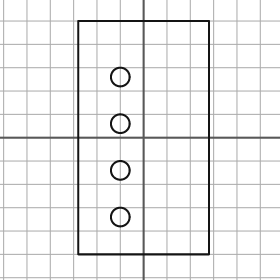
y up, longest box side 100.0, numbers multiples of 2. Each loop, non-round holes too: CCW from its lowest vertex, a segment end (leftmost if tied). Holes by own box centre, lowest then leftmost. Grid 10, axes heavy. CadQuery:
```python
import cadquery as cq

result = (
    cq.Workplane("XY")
    .moveTo(-28.0, -50.0)
    .lineTo(28.0, -50.0)
    .lineTo(28.0, 50.0)
    .lineTo(-28.0, 50.0)
    .close()
    .moveTo(-10.0, -34.0)
    .circle(4.0)
    .moveTo(-10.0, -14.0)
    .circle(4.0)
    .moveTo(-10.0, 6.0)
    .circle(4.0)
    .moveTo(-10.0, 26.0)
    .circle(4.0)
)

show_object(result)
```